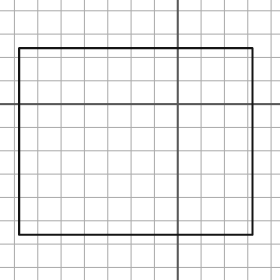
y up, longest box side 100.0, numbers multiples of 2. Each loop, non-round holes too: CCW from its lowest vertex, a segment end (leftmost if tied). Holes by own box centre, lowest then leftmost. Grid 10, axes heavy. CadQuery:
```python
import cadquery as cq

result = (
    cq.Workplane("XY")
    .moveTo(-68.0, -56.0)
    .lineTo(32.0, -56.0)
    .lineTo(32.0, 24.0)
    .lineTo(-68.0, 24.0)
    .close()
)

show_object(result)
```